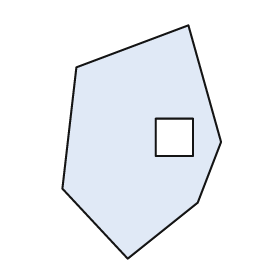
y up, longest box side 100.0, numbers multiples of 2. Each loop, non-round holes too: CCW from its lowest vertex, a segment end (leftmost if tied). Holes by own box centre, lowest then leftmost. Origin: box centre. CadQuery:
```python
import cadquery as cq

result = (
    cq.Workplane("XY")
    .moveTo(-6.0, -50.0)
    .lineTo(24.0, -26.0)
    .lineTo(34.0, 0.0)
    .lineTo(20.0, 50.0)
    .lineTo(-28.0, 32.0)
    .lineTo(-34.0, -20.0)
    .close()
    .moveTo(6.0, -6.0)
    .lineTo(22.0, -6.0)
    .lineTo(22.0, 10.0)
    .lineTo(6.0, 10.0)
    .close()
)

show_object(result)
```